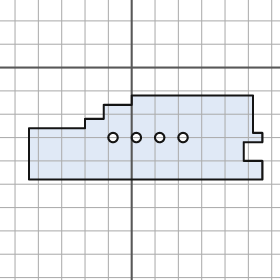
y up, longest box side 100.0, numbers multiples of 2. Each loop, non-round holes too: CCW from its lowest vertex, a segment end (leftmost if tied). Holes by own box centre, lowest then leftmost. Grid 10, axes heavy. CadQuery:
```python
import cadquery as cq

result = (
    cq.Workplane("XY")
    .moveTo(-44.0, -48.0)
    .lineTo(56.0, -48.0)
    .lineTo(56.0, -40.0)
    .lineTo(48.0, -40.0)
    .lineTo(48.0, -32.0)
    .lineTo(56.0, -32.0)
    .lineTo(56.0, -28.0)
    .lineTo(52.0, -28.0)
    .lineTo(52.0, -12.0)
    .lineTo(0.0, -12.0)
    .lineTo(0.0, -16.0)
    .lineTo(-12.0, -16.0)
    .lineTo(-12.0, -22.0)
    .lineTo(-20.0, -22.0)
    .lineTo(-20.0, -26.0)
    .lineTo(-44.0, -26.0)
    .close()
    .moveTo(-8.0, -30.0)
    .circle(2.0)
    .moveTo(2.0, -30.0)
    .circle(2.0)
    .moveTo(12.0, -30.0)
    .circle(2.0)
    .moveTo(22.0, -30.0)
    .circle(2.0)
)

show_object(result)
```